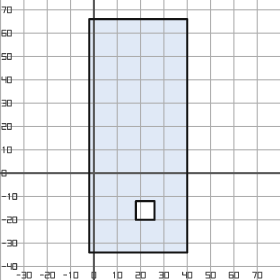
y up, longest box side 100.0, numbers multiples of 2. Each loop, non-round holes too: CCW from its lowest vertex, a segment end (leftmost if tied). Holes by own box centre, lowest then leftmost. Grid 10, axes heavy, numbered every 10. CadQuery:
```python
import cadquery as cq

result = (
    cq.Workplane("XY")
    .moveTo(-2.0, -34.0)
    .lineTo(40.0, -34.0)
    .lineTo(40.0, 66.0)
    .lineTo(-2.0, 66.0)
    .close()
    .moveTo(18.0, -20.0)
    .lineTo(26.0, -20.0)
    .lineTo(26.0, -12.0)
    .lineTo(18.0, -12.0)
    .close()
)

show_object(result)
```